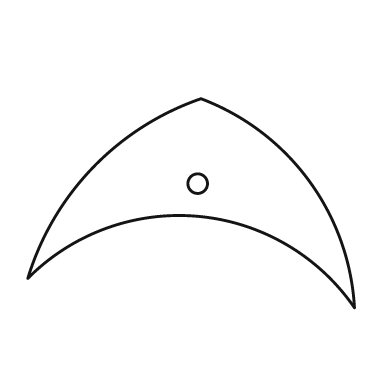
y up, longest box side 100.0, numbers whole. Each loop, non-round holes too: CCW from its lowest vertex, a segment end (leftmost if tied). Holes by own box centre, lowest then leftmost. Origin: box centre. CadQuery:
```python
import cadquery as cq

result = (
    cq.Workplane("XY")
    .moveTo(50.0, -32.0)
    .threePointArc((36.0, 7.0), (3.0, 32.0))
    .threePointArc((-30.0, 11.0), (-50.0, -23.0))
    .threePointArc((2.0, -4.0), (50.0, -32.0))
    .close()
    .moveTo(2.0, 6.0)
    .circle(3.0)
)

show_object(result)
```